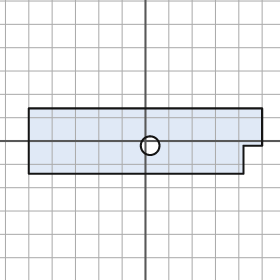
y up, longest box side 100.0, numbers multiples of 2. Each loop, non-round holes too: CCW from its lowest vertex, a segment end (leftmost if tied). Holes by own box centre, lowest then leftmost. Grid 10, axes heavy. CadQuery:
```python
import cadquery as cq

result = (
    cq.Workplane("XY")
    .moveTo(-50.0, -14.0)
    .lineTo(42.0, -14.0)
    .lineTo(42.0, -2.0)
    .lineTo(50.0, -2.0)
    .lineTo(50.0, 14.0)
    .lineTo(-50.0, 14.0)
    .close()
    .moveTo(2.0, -2.0)
    .circle(4.0)
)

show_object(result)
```